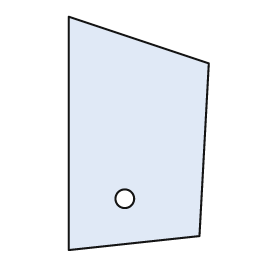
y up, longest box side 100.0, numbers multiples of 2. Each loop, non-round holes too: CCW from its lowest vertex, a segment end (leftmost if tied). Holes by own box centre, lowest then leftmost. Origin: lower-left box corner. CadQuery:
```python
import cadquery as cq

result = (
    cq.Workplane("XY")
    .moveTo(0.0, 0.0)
    .lineTo(56.0, 6.0)
    .lineTo(60.0, 80.0)
    .lineTo(0.0, 100.0)
    .close()
    .moveTo(24.0, 22.0)
    .circle(4.0)
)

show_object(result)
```